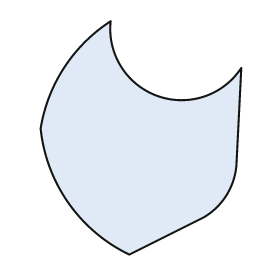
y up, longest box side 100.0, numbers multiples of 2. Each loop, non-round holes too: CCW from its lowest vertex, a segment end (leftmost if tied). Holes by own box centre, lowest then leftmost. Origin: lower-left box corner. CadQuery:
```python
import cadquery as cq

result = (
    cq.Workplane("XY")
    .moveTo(38.0, 0.0)
    .lineTo(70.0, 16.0)
    .threePointArc((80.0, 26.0), (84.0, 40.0))
    .lineTo(86.0, 80.0)
    .threePointArc((50.0, 68.0), (30.0, 100.0))
    .threePointArc((10.0, 80.0), (0.0, 54.0))
    .threePointArc((12.0, 22.0), (38.0, 0.0))
    .close()
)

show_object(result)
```